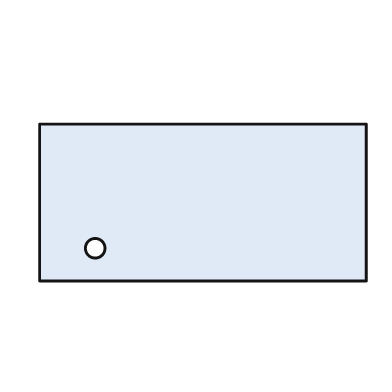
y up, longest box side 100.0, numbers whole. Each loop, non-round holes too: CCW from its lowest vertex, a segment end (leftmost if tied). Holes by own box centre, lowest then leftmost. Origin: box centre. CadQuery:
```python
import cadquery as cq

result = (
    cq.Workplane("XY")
    .moveTo(-50.0, -24.0)
    .lineTo(50.0, -24.0)
    .lineTo(50.0, 24.0)
    .lineTo(-50.0, 24.0)
    .close()
    .moveTo(-33.0, -14.0)
    .circle(3.0)
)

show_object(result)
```